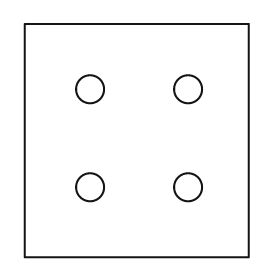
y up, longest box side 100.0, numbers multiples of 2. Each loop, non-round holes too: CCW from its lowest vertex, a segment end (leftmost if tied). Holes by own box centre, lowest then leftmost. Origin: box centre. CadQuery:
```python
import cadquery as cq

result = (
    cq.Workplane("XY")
    .moveTo(-48.0, -50.0)
    .lineTo(48.0, -50.0)
    .lineTo(48.0, 50.0)
    .lineTo(-48.0, 50.0)
    .close()
    .moveTo(-20.0, -20.0)
    .circle(6.0)
    .moveTo(22.0, -20.0)
    .circle(6.0)
    .moveTo(-20.0, 22.0)
    .circle(6.0)
    .moveTo(22.0, 22.0)
    .circle(6.0)
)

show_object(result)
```